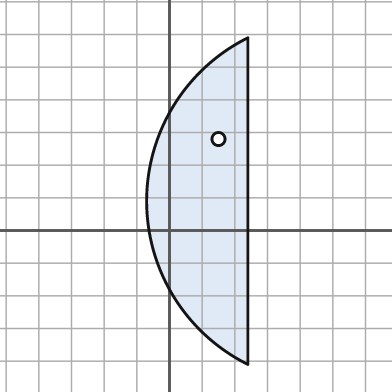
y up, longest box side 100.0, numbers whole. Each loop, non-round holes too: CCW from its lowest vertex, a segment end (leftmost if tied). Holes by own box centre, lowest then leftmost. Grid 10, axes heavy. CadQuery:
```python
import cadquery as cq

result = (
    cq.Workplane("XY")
    .moveTo(24.0, -41.0)
    .lineTo(24.0, 59.0)
    .threePointArc((-7.0, 9.0), (24.0, -41.0))
    .close()
    .moveTo(15.0, 28.0)
    .circle(2.0)
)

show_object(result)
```